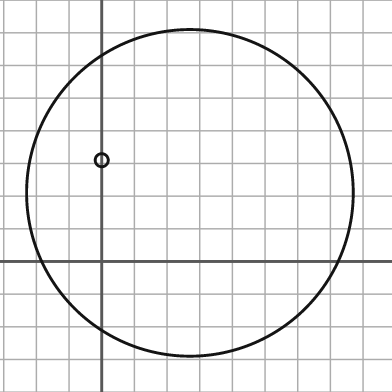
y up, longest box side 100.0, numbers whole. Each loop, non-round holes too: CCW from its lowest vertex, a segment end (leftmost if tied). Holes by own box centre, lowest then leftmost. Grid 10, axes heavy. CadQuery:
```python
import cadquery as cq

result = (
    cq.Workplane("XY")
    .moveTo(27.0, 21.0)
    .circle(50.0)
    .moveTo(0.0, 31.0)
    .circle(2.0)
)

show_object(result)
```